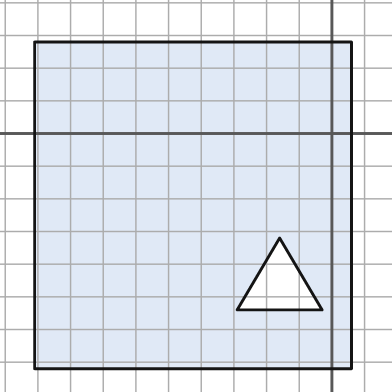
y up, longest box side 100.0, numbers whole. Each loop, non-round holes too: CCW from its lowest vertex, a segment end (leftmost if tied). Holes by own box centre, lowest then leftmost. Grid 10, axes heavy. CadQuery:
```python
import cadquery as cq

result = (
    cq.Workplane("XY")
    .moveTo(-91.0, -72.0)
    .lineTo(6.0, -72.0)
    .lineTo(6.0, 28.0)
    .lineTo(-91.0, 28.0)
    .close()
    .moveTo(-29.0, -54.0)
    .lineTo(-3.0, -54.0)
    .lineTo(-16.0, -32.0)
    .close()
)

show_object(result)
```